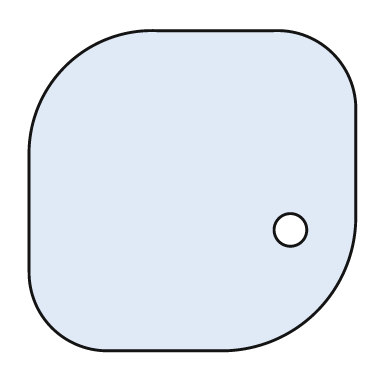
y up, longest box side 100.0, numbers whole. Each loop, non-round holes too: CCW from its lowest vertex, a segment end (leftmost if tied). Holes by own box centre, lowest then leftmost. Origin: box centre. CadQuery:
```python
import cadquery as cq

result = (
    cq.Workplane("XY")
    .moveTo(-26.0, -49.0)
    .lineTo(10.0, -49.0)
    .threePointArc((38.0, -37.0), (50.0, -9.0))
    .lineTo(50.0, 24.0)
    .threePointArc((43.0, 42.0), (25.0, 49.0))
    .lineTo(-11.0, 49.0)
    .threePointArc((-39.0, 38.0), (-50.0, 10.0))
    .lineTo(-50.0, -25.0)
    .threePointArc((-43.0, -42.0), (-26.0, -49.0))
    .close()
    .moveTo(30.0, -12.0)
    .circle(5.0)
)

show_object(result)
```